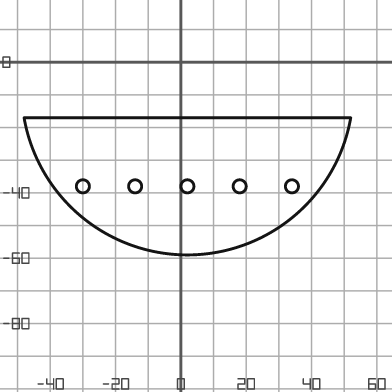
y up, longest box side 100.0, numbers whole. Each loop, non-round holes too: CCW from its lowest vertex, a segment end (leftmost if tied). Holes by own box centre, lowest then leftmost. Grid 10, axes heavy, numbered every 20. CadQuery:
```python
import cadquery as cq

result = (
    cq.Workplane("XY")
    .moveTo(-48.0, -17.0)
    .threePointArc((2.0, -59.0), (52.0, -17.0))
    .close()
    .moveTo(-30.0, -38.0)
    .circle(2.0)
    .moveTo(-14.0, -38.0)
    .circle(2.0)
    .moveTo(2.0, -38.0)
    .circle(2.0)
    .moveTo(18.0, -38.0)
    .circle(2.0)
    .moveTo(34.0, -38.0)
    .circle(2.0)
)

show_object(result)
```